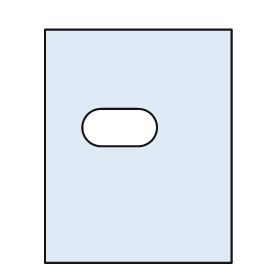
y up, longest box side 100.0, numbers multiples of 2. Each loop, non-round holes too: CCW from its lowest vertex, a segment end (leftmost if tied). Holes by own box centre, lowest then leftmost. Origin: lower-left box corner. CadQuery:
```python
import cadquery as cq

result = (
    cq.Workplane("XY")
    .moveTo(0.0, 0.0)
    .lineTo(80.0, 0.0)
    .lineTo(80.0, 100.0)
    .lineTo(0.0, 100.0)
    .close()
    .moveTo(24.0, 50.0)
    .lineTo(40.0, 50.0)
    .threePointArc((48.0, 58.0), (40.0, 66.0))
    .lineTo(24.0, 66.0)
    .threePointArc((16.0, 58.0), (24.0, 50.0))
    .close()
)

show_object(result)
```